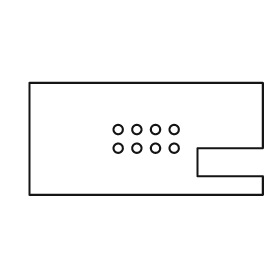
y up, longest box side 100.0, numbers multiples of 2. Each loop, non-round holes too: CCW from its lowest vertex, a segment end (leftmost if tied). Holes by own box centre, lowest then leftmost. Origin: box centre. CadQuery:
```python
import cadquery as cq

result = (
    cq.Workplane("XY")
    .moveTo(-50.0, -24.0)
    .lineTo(50.0, -24.0)
    .lineTo(50.0, -16.0)
    .lineTo(22.0, -16.0)
    .lineTo(22.0, -4.0)
    .lineTo(50.0, -4.0)
    .lineTo(50.0, 24.0)
    .lineTo(-50.0, 24.0)
    .close()
    .moveTo(-12.0, -4.0)
    .circle(2.0)
    .moveTo(-4.0, -4.0)
    .circle(2.0)
    .moveTo(4.0, -4.0)
    .circle(2.0)
    .moveTo(12.0, -4.0)
    .circle(2.0)
    .moveTo(-12.0, 4.0)
    .circle(2.0)
    .moveTo(-4.0, 4.0)
    .circle(2.0)
    .moveTo(4.0, 4.0)
    .circle(2.0)
    .moveTo(12.0, 4.0)
    .circle(2.0)
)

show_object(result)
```